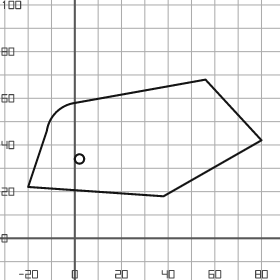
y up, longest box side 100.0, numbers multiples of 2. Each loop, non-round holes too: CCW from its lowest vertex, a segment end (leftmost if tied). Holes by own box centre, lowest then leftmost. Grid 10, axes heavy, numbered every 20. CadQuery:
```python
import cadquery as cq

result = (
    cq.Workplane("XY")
    .moveTo(38.0, 18.0)
    .lineTo(80.0, 42.0)
    .lineTo(56.0, 68.0)
    .lineTo(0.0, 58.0)
    .threePointArc((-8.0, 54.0), (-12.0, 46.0))
    .lineTo(-20.0, 22.0)
    .close()
    .moveTo(2.0, 34.0)
    .circle(2.0)
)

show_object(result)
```